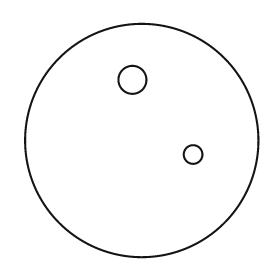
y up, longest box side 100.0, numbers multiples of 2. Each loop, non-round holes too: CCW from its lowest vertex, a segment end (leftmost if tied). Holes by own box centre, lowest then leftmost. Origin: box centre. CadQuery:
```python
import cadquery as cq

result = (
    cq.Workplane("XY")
    .moveTo(0.0, 0.0)
    .circle(50.0)
    .moveTo(22.0, -6.0)
    .circle(4.0)
    .moveTo(-4.0, 26.0)
    .circle(6.0)
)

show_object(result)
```